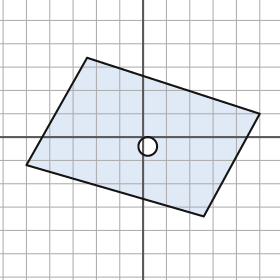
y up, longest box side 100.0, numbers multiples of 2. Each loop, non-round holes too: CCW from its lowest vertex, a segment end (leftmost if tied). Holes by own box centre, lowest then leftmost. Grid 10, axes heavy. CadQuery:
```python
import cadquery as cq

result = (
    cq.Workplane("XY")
    .moveTo(26.0, -34.0)
    .lineTo(50.0, 10.0)
    .lineTo(-24.0, 34.0)
    .lineTo(-50.0, -12.0)
    .close()
    .moveTo(2.0, -4.0)
    .circle(4.0)
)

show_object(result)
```